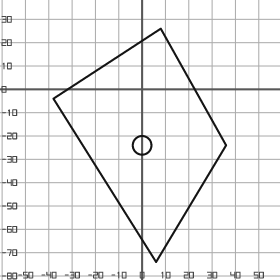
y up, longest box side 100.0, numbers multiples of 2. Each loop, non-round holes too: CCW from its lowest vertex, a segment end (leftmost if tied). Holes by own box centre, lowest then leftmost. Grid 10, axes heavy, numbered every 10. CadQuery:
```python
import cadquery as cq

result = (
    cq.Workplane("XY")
    .moveTo(6.0, -74.0)
    .lineTo(36.0, -24.0)
    .lineTo(8.0, 26.0)
    .lineTo(-38.0, -4.0)
    .close()
    .moveTo(0.0, -24.0)
    .circle(4.0)
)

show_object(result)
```